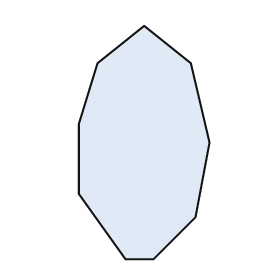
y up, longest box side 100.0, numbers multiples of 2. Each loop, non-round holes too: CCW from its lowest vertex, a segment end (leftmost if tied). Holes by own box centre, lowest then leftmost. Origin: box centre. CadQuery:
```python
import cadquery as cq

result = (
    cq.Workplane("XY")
    .moveTo(-8.0, -50.0)
    .lineTo(4.0, -50.0)
    .lineTo(22.0, -32.0)
    .lineTo(28.0, 0.0)
    .lineTo(20.0, 34.0)
    .lineTo(0.0, 50.0)
    .lineTo(-20.0, 34.0)
    .lineTo(-28.0, 8.0)
    .lineTo(-28.0, -22.0)
    .close()
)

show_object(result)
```